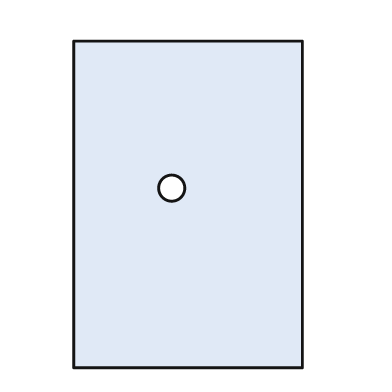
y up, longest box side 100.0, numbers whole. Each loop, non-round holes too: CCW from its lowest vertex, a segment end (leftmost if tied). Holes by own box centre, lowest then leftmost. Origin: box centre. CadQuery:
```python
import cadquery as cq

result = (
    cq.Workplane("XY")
    .moveTo(-35.0, -50.0)
    .lineTo(35.0, -50.0)
    .lineTo(35.0, 50.0)
    .lineTo(-35.0, 50.0)
    .close()
    .moveTo(-5.0, 5.0)
    .circle(4.0)
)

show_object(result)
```